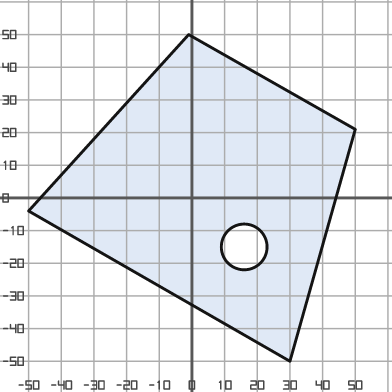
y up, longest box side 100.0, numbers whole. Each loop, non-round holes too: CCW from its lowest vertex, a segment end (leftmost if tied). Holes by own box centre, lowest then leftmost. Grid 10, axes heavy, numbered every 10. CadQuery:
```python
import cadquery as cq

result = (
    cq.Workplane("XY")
    .moveTo(30.0, -50.0)
    .lineTo(50.0, 21.0)
    .lineTo(-1.0, 50.0)
    .lineTo(-50.0, -4.0)
    .close()
    .moveTo(16.0, -15.0)
    .circle(7.0)
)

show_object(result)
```